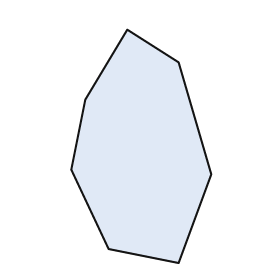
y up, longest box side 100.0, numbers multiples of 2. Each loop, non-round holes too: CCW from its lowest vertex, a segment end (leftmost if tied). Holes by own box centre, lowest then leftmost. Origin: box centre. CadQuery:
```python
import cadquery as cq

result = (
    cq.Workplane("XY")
    .moveTo(16.0, -50.0)
    .lineTo(30.0, -12.0)
    .lineTo(16.0, 36.0)
    .lineTo(-6.0, 50.0)
    .lineTo(-24.0, 20.0)
    .lineTo(-30.0, -10.0)
    .lineTo(-14.0, -44.0)
    .close()
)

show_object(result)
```